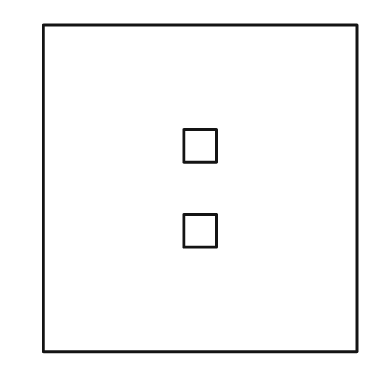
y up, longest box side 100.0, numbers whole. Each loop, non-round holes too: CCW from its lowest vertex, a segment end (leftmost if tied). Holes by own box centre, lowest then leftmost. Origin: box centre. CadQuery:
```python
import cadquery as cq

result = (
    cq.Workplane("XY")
    .moveTo(-48.0, -50.0)
    .lineTo(48.0, -50.0)
    .lineTo(48.0, 50.0)
    .lineTo(-48.0, 50.0)
    .close()
    .moveTo(-5.0, -18.0)
    .lineTo(5.0, -18.0)
    .lineTo(5.0, -8.0)
    .lineTo(-5.0, -8.0)
    .close()
    .moveTo(-5.0, 8.0)
    .lineTo(5.0, 8.0)
    .lineTo(5.0, 18.0)
    .lineTo(-5.0, 18.0)
    .close()
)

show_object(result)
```